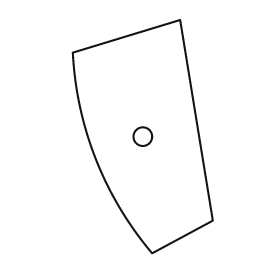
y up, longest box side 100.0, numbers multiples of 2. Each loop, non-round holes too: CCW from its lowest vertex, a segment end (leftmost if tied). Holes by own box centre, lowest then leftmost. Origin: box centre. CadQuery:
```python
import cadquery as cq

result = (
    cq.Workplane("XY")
    .moveTo(4.0, -50.0)
    .lineTo(30.0, -36.0)
    .lineTo(16.0, 50.0)
    .lineTo(-30.0, 36.0)
    .threePointArc((-20.0, -10.0), (4.0, -50.0))
    .close()
    .moveTo(0.0, 0.0)
    .circle(4.0)
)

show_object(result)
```